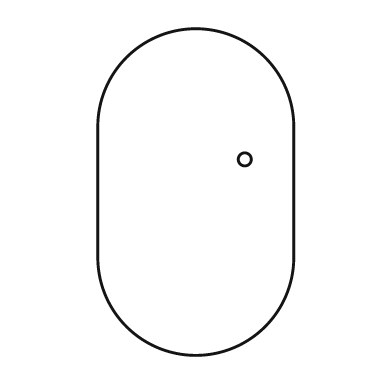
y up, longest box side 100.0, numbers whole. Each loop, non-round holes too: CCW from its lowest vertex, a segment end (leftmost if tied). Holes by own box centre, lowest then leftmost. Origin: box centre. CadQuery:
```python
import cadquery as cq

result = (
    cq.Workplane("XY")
    .moveTo(-30.0, -20.0)
    .threePointArc((0.0, -50.0), (30.0, -20.0))
    .lineTo(30.0, 20.0)
    .threePointArc((0.0, 50.0), (-30.0, 20.0))
    .close()
    .moveTo(15.0, 10.0)
    .circle(2.0)
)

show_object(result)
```